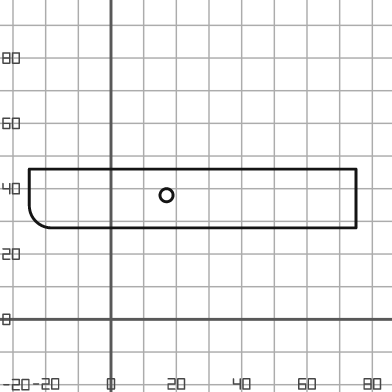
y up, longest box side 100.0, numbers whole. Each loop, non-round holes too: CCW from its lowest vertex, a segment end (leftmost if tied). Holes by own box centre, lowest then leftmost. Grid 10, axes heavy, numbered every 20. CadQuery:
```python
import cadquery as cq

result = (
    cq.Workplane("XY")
    .moveTo(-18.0, 28.0)
    .lineTo(75.0, 28.0)
    .lineTo(75.0, 46.0)
    .lineTo(-25.0, 46.0)
    .lineTo(-25.0, 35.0)
    .threePointArc((-23.0, 30.0), (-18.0, 28.0))
    .close()
    .moveTo(17.0, 38.0)
    .circle(2.0)
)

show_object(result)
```